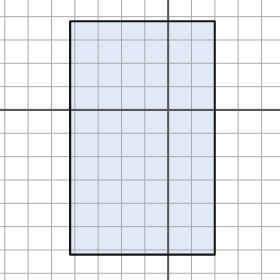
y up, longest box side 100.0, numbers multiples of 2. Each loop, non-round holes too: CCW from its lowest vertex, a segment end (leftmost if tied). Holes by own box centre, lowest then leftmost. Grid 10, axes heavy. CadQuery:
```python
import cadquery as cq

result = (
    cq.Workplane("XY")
    .moveTo(-42.0, -62.0)
    .lineTo(20.0, -62.0)
    .lineTo(20.0, 38.0)
    .lineTo(-42.0, 38.0)
    .close()
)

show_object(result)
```